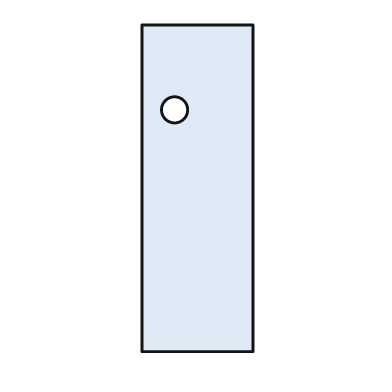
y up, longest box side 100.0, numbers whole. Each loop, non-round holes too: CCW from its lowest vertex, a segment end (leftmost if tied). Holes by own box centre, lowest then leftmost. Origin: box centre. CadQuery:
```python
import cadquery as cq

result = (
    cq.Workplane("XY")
    .moveTo(-17.0, -50.0)
    .lineTo(17.0, -50.0)
    .lineTo(17.0, 50.0)
    .lineTo(-17.0, 50.0)
    .close()
    .moveTo(-7.0, 24.0)
    .circle(4.0)
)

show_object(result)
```